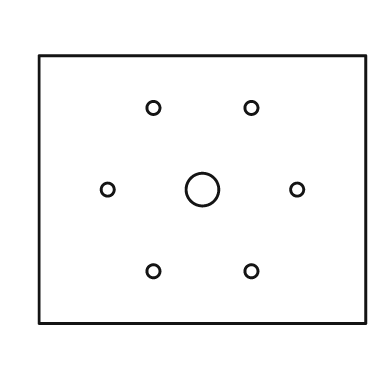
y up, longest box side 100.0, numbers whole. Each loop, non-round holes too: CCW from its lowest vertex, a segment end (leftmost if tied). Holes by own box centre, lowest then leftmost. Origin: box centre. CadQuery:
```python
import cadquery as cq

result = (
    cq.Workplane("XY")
    .moveTo(-50.0, -41.0)
    .lineTo(50.0, -41.0)
    .lineTo(50.0, 41.0)
    .lineTo(-50.0, 41.0)
    .close()
    .moveTo(-15.0, -25.0)
    .circle(2.0)
    .moveTo(15.0, -25.0)
    .circle(2.0)
    .moveTo(-29.0, 0.0)
    .circle(2.0)
    .moveTo(0.0, 0.0)
    .circle(5.0)
    .moveTo(29.0, 0.0)
    .circle(2.0)
    .moveTo(-15.0, 25.0)
    .circle(2.0)
    .moveTo(15.0, 25.0)
    .circle(2.0)
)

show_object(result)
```